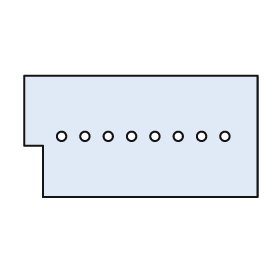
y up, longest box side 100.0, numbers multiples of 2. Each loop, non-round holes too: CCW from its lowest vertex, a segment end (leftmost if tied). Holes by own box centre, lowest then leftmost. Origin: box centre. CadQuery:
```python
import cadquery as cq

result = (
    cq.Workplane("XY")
    .moveTo(-42.0, -26.0)
    .lineTo(50.0, -26.0)
    .lineTo(50.0, 26.0)
    .lineTo(-50.0, 26.0)
    .lineTo(-50.0, -4.0)
    .lineTo(-42.0, -4.0)
    .close()
    .moveTo(-34.0, 0.0)
    .circle(2.0)
    .moveTo(-24.0, 0.0)
    .circle(2.0)
    .moveTo(-14.0, 0.0)
    .circle(2.0)
    .moveTo(-4.0, 0.0)
    .circle(2.0)
    .moveTo(6.0, 0.0)
    .circle(2.0)
    .moveTo(16.0, 0.0)
    .circle(2.0)
    .moveTo(26.0, 0.0)
    .circle(2.0)
    .moveTo(36.0, 0.0)
    .circle(2.0)
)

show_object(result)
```